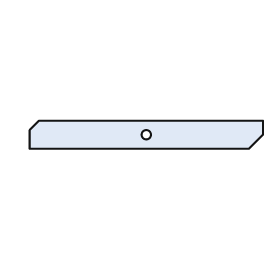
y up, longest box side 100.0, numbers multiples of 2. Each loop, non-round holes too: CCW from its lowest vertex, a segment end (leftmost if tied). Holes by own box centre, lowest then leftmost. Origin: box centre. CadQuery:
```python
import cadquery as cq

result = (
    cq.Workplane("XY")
    .moveTo(-50.0, -6.0)
    .lineTo(44.0, -6.0)
    .lineTo(50.0, 0.0)
    .lineTo(50.0, 6.0)
    .lineTo(-46.0, 6.0)
    .lineTo(-50.0, 2.0)
    .close()
    .moveTo(0.0, 0.0)
    .circle(2.0)
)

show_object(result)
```